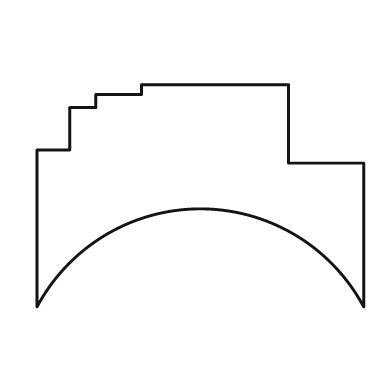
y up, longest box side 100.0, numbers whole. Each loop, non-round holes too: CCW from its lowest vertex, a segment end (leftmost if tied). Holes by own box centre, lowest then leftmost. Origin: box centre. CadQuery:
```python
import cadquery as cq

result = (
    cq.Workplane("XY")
    .moveTo(-50.0, -34.0)
    .threePointArc((0.0, -4.0), (50.0, -34.0))
    .lineTo(50.0, 10.0)
    .lineTo(27.0, 10.0)
    .lineTo(27.0, 34.0)
    .lineTo(-18.0, 34.0)
    .lineTo(-18.0, 31.0)
    .lineTo(-32.0, 31.0)
    .lineTo(-32.0, 27.0)
    .lineTo(-40.0, 27.0)
    .lineTo(-40.0, 14.0)
    .lineTo(-50.0, 14.0)
    .close()
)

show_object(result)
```